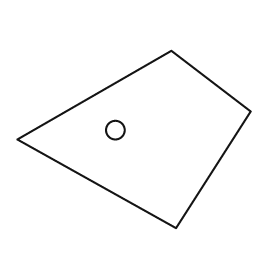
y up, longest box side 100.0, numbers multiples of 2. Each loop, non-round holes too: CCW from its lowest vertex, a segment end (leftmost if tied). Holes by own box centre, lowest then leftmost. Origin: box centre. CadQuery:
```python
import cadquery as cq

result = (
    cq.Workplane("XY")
    .moveTo(18.0, -38.0)
    .lineTo(50.0, 12.0)
    .lineTo(16.0, 38.0)
    .lineTo(-50.0, 0.0)
    .close()
    .moveTo(-8.0, 4.0)
    .circle(4.0)
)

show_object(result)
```